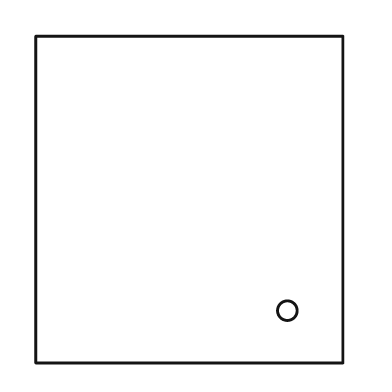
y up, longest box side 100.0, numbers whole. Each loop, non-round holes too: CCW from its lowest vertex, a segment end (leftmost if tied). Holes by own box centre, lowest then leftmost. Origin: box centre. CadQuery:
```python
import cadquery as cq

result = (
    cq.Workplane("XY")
    .moveTo(-47.0, -50.0)
    .lineTo(47.0, -50.0)
    .lineTo(47.0, 50.0)
    .lineTo(-47.0, 50.0)
    .close()
    .moveTo(30.0, -34.0)
    .circle(3.0)
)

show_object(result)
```